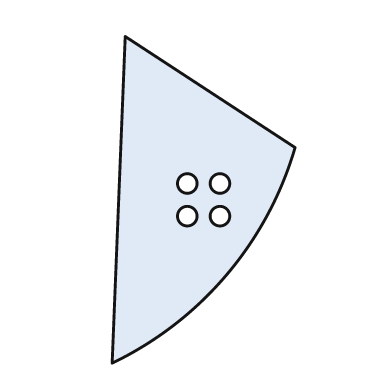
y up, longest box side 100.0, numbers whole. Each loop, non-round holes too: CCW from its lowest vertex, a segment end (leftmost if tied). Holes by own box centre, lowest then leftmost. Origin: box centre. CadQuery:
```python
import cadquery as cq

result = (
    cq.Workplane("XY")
    .moveTo(-28.0, -50.0)
    .threePointArc((7.0, -23.0), (28.0, 16.0))
    .lineTo(-24.0, 50.0)
    .close()
    .moveTo(-5.0, -5.0)
    .circle(3.0)
    .moveTo(5.0, -5.0)
    .circle(3.0)
    .moveTo(-5.0, 5.0)
    .circle(3.0)
    .moveTo(5.0, 5.0)
    .circle(3.0)
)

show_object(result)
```